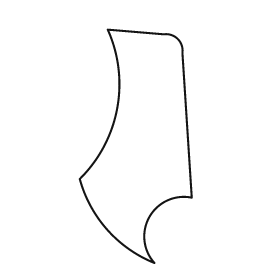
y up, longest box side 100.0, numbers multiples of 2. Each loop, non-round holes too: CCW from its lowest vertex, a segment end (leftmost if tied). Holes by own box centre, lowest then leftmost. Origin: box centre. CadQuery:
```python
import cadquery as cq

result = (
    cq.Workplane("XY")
    .moveTo(8.0, -50.0)
    .threePointArc((6.0, -30.0), (24.0, -22.0))
    .lineTo(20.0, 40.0)
    .threePointArc((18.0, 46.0), (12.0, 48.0))
    .lineTo(-12.0, 50.0)
    .threePointArc((-8.0, 16.0), (-24.0, -14.0))
    .threePointArc((-12.0, -36.0), (8.0, -50.0))
    .close()
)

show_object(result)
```